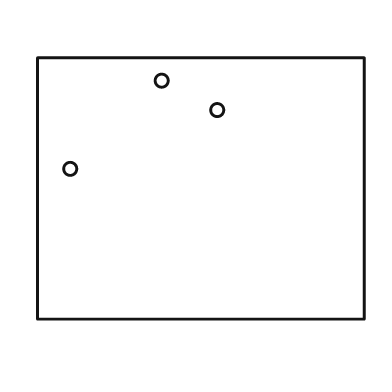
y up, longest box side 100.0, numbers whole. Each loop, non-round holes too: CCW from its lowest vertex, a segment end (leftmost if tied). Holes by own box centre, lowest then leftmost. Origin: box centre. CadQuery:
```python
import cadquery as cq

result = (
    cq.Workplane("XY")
    .moveTo(-50.0, -40.0)
    .lineTo(50.0, -40.0)
    .lineTo(50.0, 40.0)
    .lineTo(-50.0, 40.0)
    .close()
    .moveTo(-40.0, 6.0)
    .circle(2.0)
    .moveTo(5.0, 24.0)
    .circle(2.0)
    .moveTo(-12.0, 33.0)
    .circle(2.0)
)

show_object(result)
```